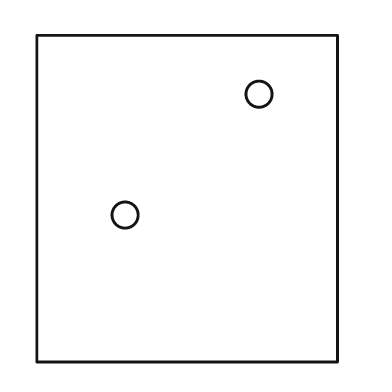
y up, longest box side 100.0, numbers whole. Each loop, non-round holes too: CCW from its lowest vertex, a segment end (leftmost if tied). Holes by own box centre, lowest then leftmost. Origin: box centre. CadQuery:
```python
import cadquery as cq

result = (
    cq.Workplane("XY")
    .moveTo(-46.0, -50.0)
    .lineTo(46.0, -50.0)
    .lineTo(46.0, 50.0)
    .lineTo(-46.0, 50.0)
    .close()
    .moveTo(-19.0, -5.0)
    .circle(4.0)
    .moveTo(22.0, 32.0)
    .circle(4.0)
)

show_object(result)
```